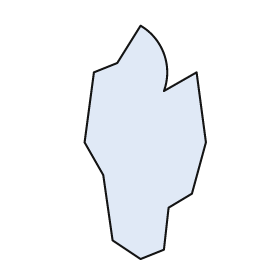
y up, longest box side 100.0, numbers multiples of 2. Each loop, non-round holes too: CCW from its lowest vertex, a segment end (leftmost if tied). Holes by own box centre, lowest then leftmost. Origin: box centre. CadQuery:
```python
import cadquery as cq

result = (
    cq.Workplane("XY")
    .moveTo(-2.0, -50.0)
    .lineTo(8.0, -46.0)
    .lineTo(10.0, -28.0)
    .lineTo(20.0, -22.0)
    .lineTo(26.0, 0.0)
    .lineTo(22.0, 30.0)
    .lineTo(8.0, 22.0)
    .threePointArc((8.0, 38.0), (-2.0, 50.0))
    .lineTo(-12.0, 34.0)
    .lineTo(-22.0, 30.0)
    .lineTo(-26.0, 0.0)
    .lineTo(-18.0, -14.0)
    .lineTo(-14.0, -42.0)
    .close()
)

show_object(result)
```